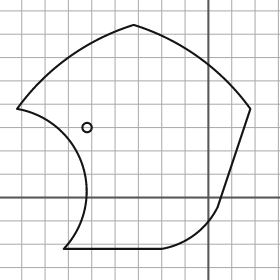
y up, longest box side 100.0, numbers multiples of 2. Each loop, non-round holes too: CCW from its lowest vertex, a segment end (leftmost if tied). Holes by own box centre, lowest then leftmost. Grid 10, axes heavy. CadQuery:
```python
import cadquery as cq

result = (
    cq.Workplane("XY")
    .moveTo(-62.0, -22.0)
    .lineTo(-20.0, -22.0)
    .threePointArc((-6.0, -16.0), (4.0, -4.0))
    .lineTo(18.0, 38.0)
    .threePointArc((-4.0, 60.0), (-32.0, 74.0))
    .threePointArc((-60.0, 60.0), (-82.0, 38.0))
    .threePointArc((-54.0, 14.0), (-62.0, -22.0))
    .close()
    .moveTo(-52.0, 30.0)
    .circle(2.0)
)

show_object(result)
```